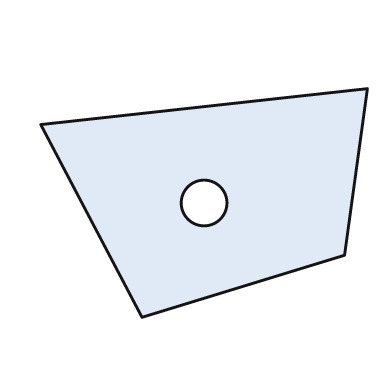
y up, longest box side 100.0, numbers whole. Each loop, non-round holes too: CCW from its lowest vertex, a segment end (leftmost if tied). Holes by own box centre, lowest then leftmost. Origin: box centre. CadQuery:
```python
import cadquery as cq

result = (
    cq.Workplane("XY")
    .moveTo(-19.0, -35.0)
    .lineTo(43.0, -16.0)
    .lineTo(50.0, 35.0)
    .lineTo(-50.0, 24.0)
    .close()
    .moveTo(0.0, 0.0)
    .circle(7.0)
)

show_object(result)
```